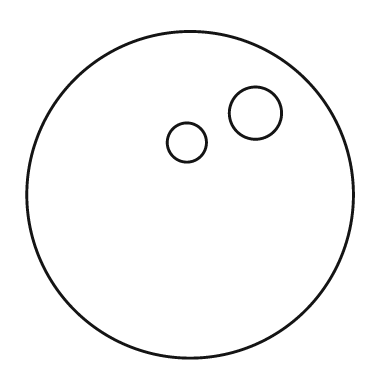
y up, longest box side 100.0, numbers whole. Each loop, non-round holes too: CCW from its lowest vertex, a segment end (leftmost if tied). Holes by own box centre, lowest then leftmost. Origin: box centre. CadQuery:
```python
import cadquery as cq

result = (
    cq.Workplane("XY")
    .moveTo(0.0, 0.0)
    .circle(50.0)
    .moveTo(-1.0, 16.0)
    .circle(6.0)
    .moveTo(20.0, 25.0)
    .circle(8.0)
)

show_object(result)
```